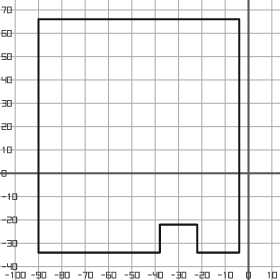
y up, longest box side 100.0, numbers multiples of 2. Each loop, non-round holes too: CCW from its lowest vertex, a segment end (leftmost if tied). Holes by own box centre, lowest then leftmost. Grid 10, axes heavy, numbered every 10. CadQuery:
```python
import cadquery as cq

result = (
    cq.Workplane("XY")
    .moveTo(-90.0, -34.0)
    .lineTo(-38.0, -34.0)
    .lineTo(-38.0, -22.0)
    .lineTo(-22.0, -22.0)
    .lineTo(-22.0, -34.0)
    .lineTo(-4.0, -34.0)
    .lineTo(-4.0, 66.0)
    .lineTo(-90.0, 66.0)
    .close()
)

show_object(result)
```